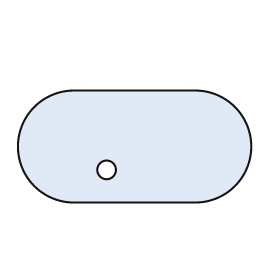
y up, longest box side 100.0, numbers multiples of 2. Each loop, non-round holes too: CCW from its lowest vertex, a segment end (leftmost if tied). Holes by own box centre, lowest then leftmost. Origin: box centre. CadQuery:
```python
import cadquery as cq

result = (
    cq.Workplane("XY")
    .moveTo(-26.0, -24.0)
    .lineTo(26.0, -24.0)
    .threePointArc((50.0, 0.0), (26.0, 24.0))
    .lineTo(-26.0, 24.0)
    .threePointArc((-50.0, 0.0), (-26.0, -24.0))
    .close()
    .moveTo(-12.0, -10.0)
    .circle(4.0)
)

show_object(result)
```